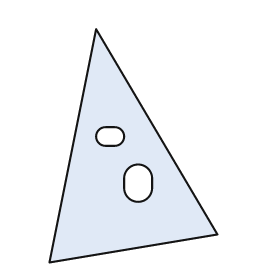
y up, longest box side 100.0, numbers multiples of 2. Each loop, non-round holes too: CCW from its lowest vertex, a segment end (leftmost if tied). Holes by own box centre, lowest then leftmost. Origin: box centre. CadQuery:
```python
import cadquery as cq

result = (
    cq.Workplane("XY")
    .moveTo(-36.0, -50.0)
    .lineTo(36.0, -38.0)
    .lineTo(-16.0, 50.0)
    .close()
    .moveTo(-4.0, -18.0)
    .threePointArc((2.0, -24.0), (8.0, -18.0))
    .lineTo(8.0, -14.0)
    .threePointArc((2.0, -8.0), (-4.0, -14.0))
    .close()
    .moveTo(-12.0, 0.0)
    .lineTo(-8.0, 0.0)
    .threePointArc((-4.0, 4.0), (-8.0, 8.0))
    .lineTo(-12.0, 8.0)
    .threePointArc((-16.0, 4.0), (-12.0, 0.0))
    .close()
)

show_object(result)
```